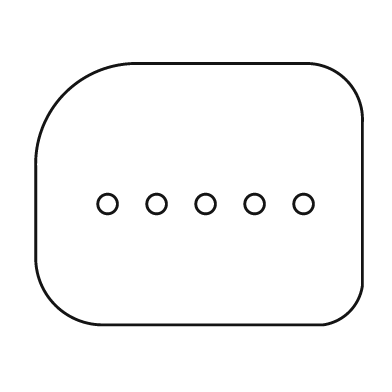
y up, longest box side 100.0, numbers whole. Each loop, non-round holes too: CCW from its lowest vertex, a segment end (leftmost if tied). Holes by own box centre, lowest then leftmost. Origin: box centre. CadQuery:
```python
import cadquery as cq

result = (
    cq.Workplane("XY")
    .moveTo(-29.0, -40.0)
    .lineTo(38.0, -40.0)
    .threePointArc((46.0, -36.0), (50.0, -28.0))
    .lineTo(50.0, 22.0)
    .threePointArc((45.0, 35.0), (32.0, 40.0))
    .lineTo(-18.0, 40.0)
    .threePointArc((-41.0, 31.0), (-50.0, 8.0))
    .lineTo(-50.0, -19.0)
    .threePointArc((-44.0, -34.0), (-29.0, -40.0))
    .close()
    .moveTo(-28.0, -3.0)
    .circle(3.0)
    .moveTo(-13.0, -3.0)
    .circle(3.0)
    .moveTo(2.0, -3.0)
    .circle(3.0)
    .moveTo(17.0, -3.0)
    .circle(3.0)
    .moveTo(32.0, -3.0)
    .circle(3.0)
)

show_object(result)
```